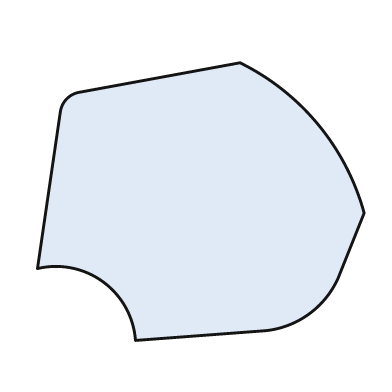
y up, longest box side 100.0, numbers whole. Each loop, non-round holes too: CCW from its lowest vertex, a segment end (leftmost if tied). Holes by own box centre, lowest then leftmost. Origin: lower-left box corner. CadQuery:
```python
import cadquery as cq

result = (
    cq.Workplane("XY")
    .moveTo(30.0, 0.0)
    .lineTo(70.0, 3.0)
    .threePointArc((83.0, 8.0), (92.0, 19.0))
    .lineTo(100.0, 39.0)
    .threePointArc((86.0, 66.0), (62.0, 85.0))
    .lineTo(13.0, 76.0)
    .threePointArc((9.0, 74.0), (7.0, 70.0))
    .lineTo(0.0, 22.0)
    .threePointArc((20.0, 18.0), (30.0, 0.0))
    .close()
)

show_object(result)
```